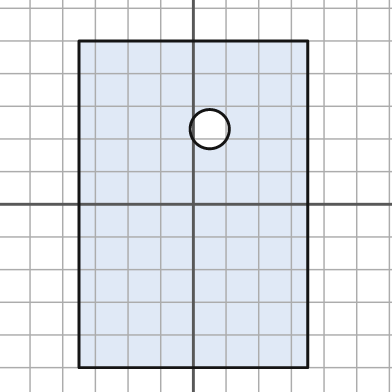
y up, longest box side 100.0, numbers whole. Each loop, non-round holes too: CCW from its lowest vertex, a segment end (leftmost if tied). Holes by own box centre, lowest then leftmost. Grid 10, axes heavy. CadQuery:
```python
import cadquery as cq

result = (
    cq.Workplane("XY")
    .moveTo(-35.0, -50.0)
    .lineTo(35.0, -50.0)
    .lineTo(35.0, 50.0)
    .lineTo(-35.0, 50.0)
    .close()
    .moveTo(5.0, 23.0)
    .circle(6.0)
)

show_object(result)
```